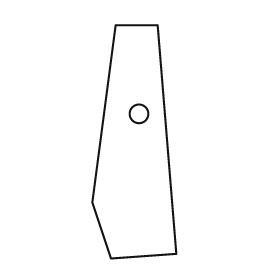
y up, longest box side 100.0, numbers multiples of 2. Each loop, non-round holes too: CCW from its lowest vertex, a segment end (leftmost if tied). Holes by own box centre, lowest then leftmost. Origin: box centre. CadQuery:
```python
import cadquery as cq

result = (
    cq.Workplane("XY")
    .moveTo(-10.0, -50.0)
    .lineTo(18.0, -48.0)
    .lineTo(10.0, 50.0)
    .lineTo(-8.0, 50.0)
    .lineTo(-18.0, -26.0)
    .close()
    .moveTo(2.0, 12.0)
    .circle(4.0)
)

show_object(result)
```